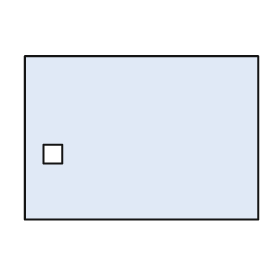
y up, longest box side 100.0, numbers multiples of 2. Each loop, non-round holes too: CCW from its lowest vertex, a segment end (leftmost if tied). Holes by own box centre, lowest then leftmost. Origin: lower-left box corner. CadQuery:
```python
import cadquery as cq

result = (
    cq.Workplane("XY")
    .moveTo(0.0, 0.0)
    .lineTo(100.0, 0.0)
    .lineTo(100.0, 70.0)
    .lineTo(0.0, 70.0)
    .close()
    .moveTo(8.0, 24.0)
    .lineTo(16.0, 24.0)
    .lineTo(16.0, 32.0)
    .lineTo(8.0, 32.0)
    .close()
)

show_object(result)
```